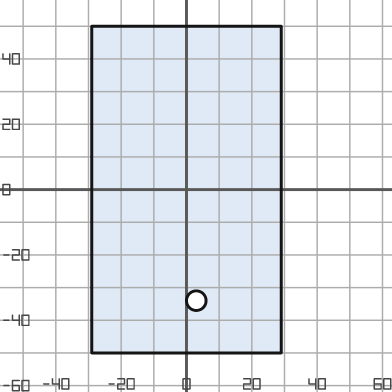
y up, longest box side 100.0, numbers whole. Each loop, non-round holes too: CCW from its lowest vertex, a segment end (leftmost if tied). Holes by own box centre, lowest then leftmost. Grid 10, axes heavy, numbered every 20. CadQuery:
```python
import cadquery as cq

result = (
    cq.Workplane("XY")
    .moveTo(-29.0, -50.0)
    .lineTo(29.0, -50.0)
    .lineTo(29.0, 50.0)
    .lineTo(-29.0, 50.0)
    .close()
    .moveTo(3.0, -34.0)
    .circle(3.0)
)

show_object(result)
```